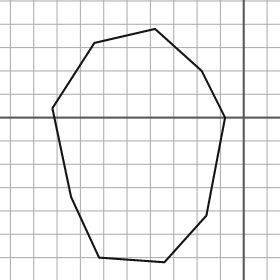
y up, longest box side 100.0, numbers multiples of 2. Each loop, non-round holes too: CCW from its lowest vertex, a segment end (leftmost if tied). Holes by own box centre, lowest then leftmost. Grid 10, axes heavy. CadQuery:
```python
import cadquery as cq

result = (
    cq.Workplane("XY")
    .moveTo(-34.0, -62.0)
    .lineTo(-16.0, -42.0)
    .lineTo(-8.0, 0.0)
    .lineTo(-18.0, 20.0)
    .lineTo(-38.0, 38.0)
    .lineTo(-64.0, 32.0)
    .lineTo(-82.0, 4.0)
    .lineTo(-74.0, -34.0)
    .lineTo(-62.0, -60.0)
    .close()
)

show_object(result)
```